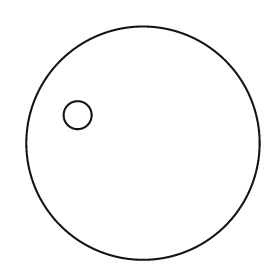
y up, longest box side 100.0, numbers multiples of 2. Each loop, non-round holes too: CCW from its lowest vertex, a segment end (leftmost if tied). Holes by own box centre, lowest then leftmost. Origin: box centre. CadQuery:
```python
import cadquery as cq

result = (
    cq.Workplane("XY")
    .moveTo(0.0, 0.0)
    .circle(50.0)
    .moveTo(-28.0, 12.0)
    .circle(6.0)
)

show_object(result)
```